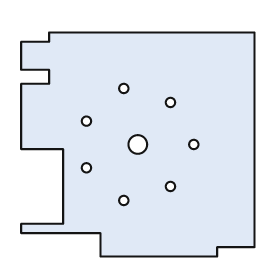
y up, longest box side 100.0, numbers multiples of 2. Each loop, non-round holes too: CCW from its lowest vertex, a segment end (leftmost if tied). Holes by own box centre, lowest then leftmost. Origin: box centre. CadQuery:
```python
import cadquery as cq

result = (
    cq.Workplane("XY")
    .moveTo(-16.0, -48.0)
    .lineTo(34.0, -48.0)
    .lineTo(34.0, -44.0)
    .lineTo(50.0, -44.0)
    .lineTo(50.0, 48.0)
    .lineTo(-38.0, 48.0)
    .lineTo(-38.0, 44.0)
    .lineTo(-50.0, 44.0)
    .lineTo(-50.0, 32.0)
    .lineTo(-38.0, 32.0)
    .lineTo(-38.0, 26.0)
    .lineTo(-50.0, 26.0)
    .lineTo(-50.0, -2.0)
    .lineTo(-32.0, -2.0)
    .lineTo(-32.0, -34.0)
    .lineTo(-50.0, -34.0)
    .lineTo(-50.0, -38.0)
    .lineTo(-16.0, -38.0)
    .close()
    .moveTo(-6.0, -24.0)
    .circle(2.0)
    .moveTo(14.0, -18.0)
    .circle(2.0)
    .moveTo(-22.0, -10.0)
    .circle(2.0)
    .moveTo(0.0, 0.0)
    .circle(4.0)
    .moveTo(24.0, 0.0)
    .circle(2.0)
    .moveTo(-22.0, 10.0)
    .circle(2.0)
    .moveTo(14.0, 18.0)
    .circle(2.0)
    .moveTo(-6.0, 24.0)
    .circle(2.0)
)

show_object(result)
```